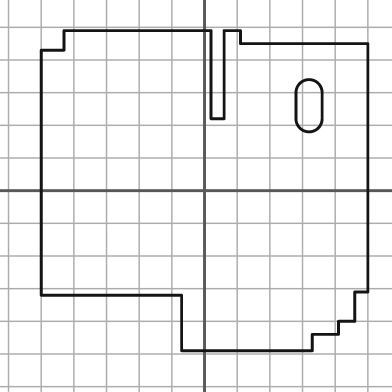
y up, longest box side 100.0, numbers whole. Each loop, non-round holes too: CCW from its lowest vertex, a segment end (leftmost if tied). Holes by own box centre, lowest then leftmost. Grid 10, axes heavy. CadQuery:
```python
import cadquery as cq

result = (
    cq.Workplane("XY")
    .moveTo(-7.0, -49.0)
    .lineTo(33.0, -49.0)
    .lineTo(33.0, -44.0)
    .lineTo(41.0, -44.0)
    .lineTo(41.0, -40.0)
    .lineTo(46.0, -40.0)
    .lineTo(46.0, -31.0)
    .lineTo(50.0, -31.0)
    .lineTo(50.0, 45.0)
    .lineTo(11.0, 45.0)
    .lineTo(11.0, 49.0)
    .lineTo(6.0, 49.0)
    .lineTo(6.0, 22.0)
    .lineTo(2.0, 22.0)
    .lineTo(2.0, 49.0)
    .lineTo(-43.0, 49.0)
    .lineTo(-43.0, 43.0)
    .lineTo(-50.0, 43.0)
    .lineTo(-50.0, -32.0)
    .lineTo(-7.0, -32.0)
    .close()
    .moveTo(28.0, 22.0)
    .threePointArc((32.0, 18.0), (36.0, 22.0))
    .lineTo(36.0, 30.0)
    .threePointArc((32.0, 34.0), (28.0, 30.0))
    .close()
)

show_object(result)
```